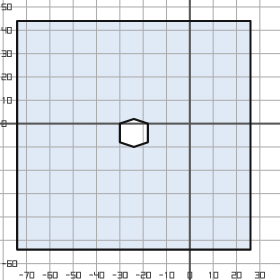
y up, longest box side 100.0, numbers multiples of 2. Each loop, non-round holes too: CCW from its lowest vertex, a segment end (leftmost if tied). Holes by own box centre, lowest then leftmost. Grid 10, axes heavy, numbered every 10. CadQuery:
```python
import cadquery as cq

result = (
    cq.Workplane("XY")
    .moveTo(-74.0, -54.0)
    .lineTo(26.0, -54.0)
    .lineTo(26.0, 44.0)
    .lineTo(-74.0, 44.0)
    .close()
    .moveTo(-24.0, -10.0)
    .lineTo(-18.0, -8.0)
    .lineTo(-18.0, 0.0)
    .lineTo(-24.0, 2.0)
    .lineTo(-30.0, 0.0)
    .lineTo(-30.0, -8.0)
    .close()
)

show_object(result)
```